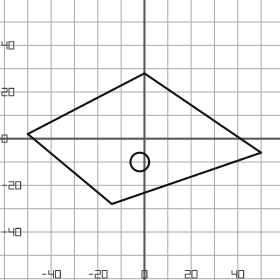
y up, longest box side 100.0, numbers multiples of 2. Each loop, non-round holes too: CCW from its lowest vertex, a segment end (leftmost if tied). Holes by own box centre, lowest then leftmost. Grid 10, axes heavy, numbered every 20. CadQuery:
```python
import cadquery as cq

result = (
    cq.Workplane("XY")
    .moveTo(-14.0, -28.0)
    .lineTo(50.0, -6.0)
    .lineTo(0.0, 28.0)
    .lineTo(-50.0, 2.0)
    .close()
    .moveTo(-2.0, -10.0)
    .circle(4.0)
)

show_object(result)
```